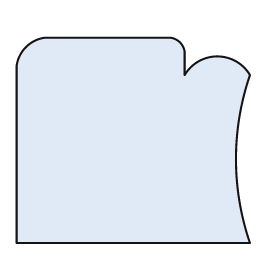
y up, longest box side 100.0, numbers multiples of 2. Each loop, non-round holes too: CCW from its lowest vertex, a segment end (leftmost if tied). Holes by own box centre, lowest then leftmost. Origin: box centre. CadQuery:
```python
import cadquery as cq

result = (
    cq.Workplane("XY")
    .moveTo(-50.0, -44.0)
    .lineTo(50.0, -44.0)
    .threePointArc((44.0, -8.0), (50.0, 28.0))
    .threePointArc((36.0, 36.0), (22.0, 28.0))
    .lineTo(22.0, 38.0)
    .threePointArc((20.0, 42.0), (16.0, 44.0))
    .lineTo(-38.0, 44.0)
    .threePointArc((-46.0, 40.0), (-50.0, 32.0))
    .close()
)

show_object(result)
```